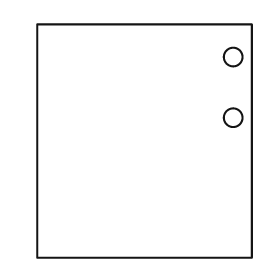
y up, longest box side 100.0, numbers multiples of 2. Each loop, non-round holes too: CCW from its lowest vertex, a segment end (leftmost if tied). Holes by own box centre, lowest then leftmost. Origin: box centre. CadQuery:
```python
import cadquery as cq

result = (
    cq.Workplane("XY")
    .moveTo(-46.0, -50.0)
    .lineTo(46.0, -50.0)
    .lineTo(46.0, 50.0)
    .lineTo(-46.0, 50.0)
    .close()
    .moveTo(38.0, 10.0)
    .circle(4.0)
    .moveTo(38.0, 36.0)
    .circle(4.0)
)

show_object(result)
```